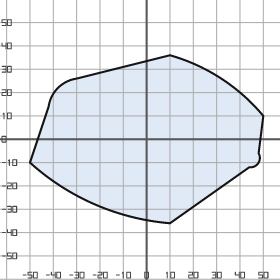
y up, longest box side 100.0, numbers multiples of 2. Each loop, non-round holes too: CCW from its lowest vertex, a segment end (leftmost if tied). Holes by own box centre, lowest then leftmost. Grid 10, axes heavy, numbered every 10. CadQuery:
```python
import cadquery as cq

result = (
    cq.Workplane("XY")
    .moveTo(10.0, -36.0)
    .lineTo(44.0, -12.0)
    .threePointArc((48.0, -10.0), (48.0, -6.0))
    .lineTo(50.0, 10.0)
    .threePointArc((32.0, 26.0), (10.0, 36.0))
    .lineTo(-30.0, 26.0)
    .threePointArc((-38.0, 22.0), (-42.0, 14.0))
    .lineTo(-50.0, -10.0)
    .threePointArc((-22.0, -28.0), (10.0, -36.0))
    .close()
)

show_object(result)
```